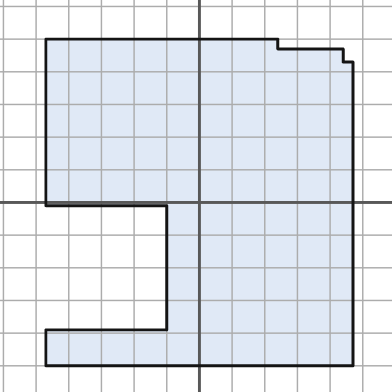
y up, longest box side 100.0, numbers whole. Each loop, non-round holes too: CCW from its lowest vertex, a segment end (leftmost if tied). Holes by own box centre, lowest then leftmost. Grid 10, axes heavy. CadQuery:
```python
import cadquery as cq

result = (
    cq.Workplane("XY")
    .moveTo(-47.0, -50.0)
    .lineTo(47.0, -50.0)
    .lineTo(47.0, 43.0)
    .lineTo(44.0, 43.0)
    .lineTo(44.0, 47.0)
    .lineTo(24.0, 47.0)
    .lineTo(24.0, 50.0)
    .lineTo(-47.0, 50.0)
    .lineTo(-47.0, -1.0)
    .lineTo(-10.0, -1.0)
    .lineTo(-10.0, -39.0)
    .lineTo(-47.0, -39.0)
    .close()
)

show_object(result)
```